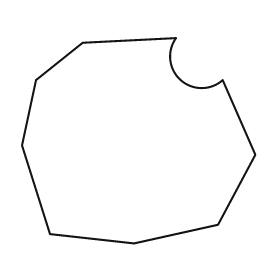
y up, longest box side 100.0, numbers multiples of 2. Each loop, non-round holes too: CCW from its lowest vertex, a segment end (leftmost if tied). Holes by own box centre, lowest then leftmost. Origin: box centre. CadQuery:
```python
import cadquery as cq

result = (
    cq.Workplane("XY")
    .moveTo(-2.0, -44.0)
    .lineTo(34.0, -36.0)
    .lineTo(50.0, -6.0)
    .lineTo(36.0, 26.0)
    .threePointArc((18.0, 26.0), (16.0, 44.0))
    .lineTo(-24.0, 42.0)
    .lineTo(-44.0, 26.0)
    .lineTo(-50.0, -2.0)
    .lineTo(-38.0, -40.0)
    .close()
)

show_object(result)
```